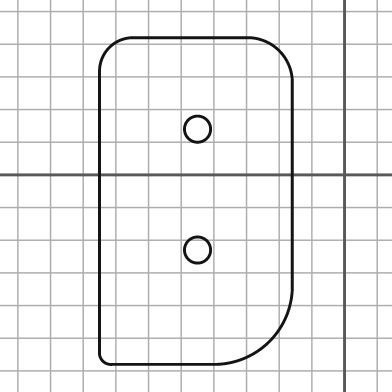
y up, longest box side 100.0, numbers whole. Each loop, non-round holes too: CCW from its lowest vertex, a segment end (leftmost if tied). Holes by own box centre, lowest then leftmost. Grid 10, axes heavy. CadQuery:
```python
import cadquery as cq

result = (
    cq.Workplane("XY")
    .moveTo(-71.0, -58.0)
    .lineTo(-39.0, -58.0)
    .threePointArc((-23.0, -51.0), (-16.0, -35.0))
    .lineTo(-16.0, 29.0)
    .threePointArc((-20.0, 38.0), (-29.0, 42.0))
    .lineTo(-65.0, 42.0)
    .threePointArc((-72.0, 39.0), (-75.0, 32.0))
    .lineTo(-75.0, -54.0)
    .threePointArc((-74.0, -57.0), (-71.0, -58.0))
    .close()
    .moveTo(-45.0, -23.0)
    .circle(4.0)
    .moveTo(-45.0, 14.0)
    .circle(4.0)
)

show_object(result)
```